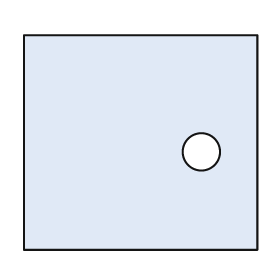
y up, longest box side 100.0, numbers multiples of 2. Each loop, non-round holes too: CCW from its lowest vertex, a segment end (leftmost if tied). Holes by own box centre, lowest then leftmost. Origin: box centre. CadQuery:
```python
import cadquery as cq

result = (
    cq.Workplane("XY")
    .moveTo(-50.0, -46.0)
    .lineTo(50.0, -46.0)
    .lineTo(50.0, 46.0)
    .lineTo(-50.0, 46.0)
    .close()
    .moveTo(26.0, -4.0)
    .circle(8.0)
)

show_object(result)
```